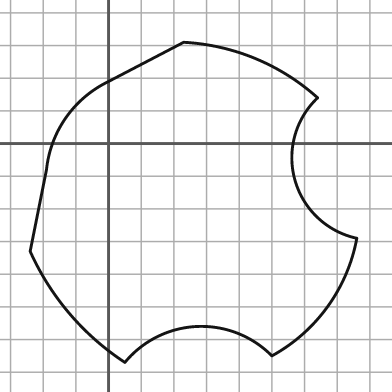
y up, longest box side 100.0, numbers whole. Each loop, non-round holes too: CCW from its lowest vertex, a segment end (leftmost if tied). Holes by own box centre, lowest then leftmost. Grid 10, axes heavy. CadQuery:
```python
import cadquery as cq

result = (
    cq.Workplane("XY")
    .moveTo(5.0, -67.0)
    .threePointArc((27.0, -56.0), (50.0, -65.0))
    .threePointArc((67.0, -50.0), (76.0, -29.0))
    .threePointArc((57.0, -11.0), (64.0, 14.0))
    .threePointArc((45.0, 26.0), (23.0, 31.0))
    .lineTo(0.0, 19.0)
    .threePointArc((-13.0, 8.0), (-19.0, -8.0))
    .lineTo(-24.0, -33.0)
    .threePointArc((-12.0, -52.0), (5.0, -67.0))
    .close()
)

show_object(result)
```